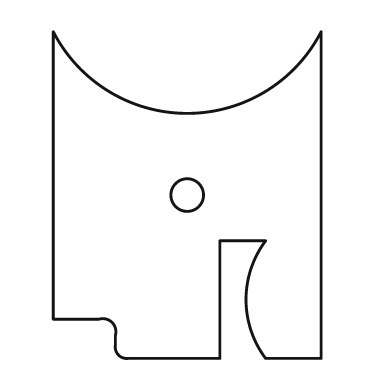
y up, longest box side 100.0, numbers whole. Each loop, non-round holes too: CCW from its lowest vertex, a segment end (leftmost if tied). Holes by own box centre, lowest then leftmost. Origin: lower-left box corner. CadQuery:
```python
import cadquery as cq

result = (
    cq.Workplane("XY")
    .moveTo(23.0, 0.0)
    .lineTo(51.0, 0.0)
    .lineTo(51.0, 36.0)
    .lineTo(65.0, 36.0)
    .threePointArc((59.0, 18.0), (65.0, 0.0))
    .lineTo(82.0, 0.0)
    .lineTo(82.0, 100.0)
    .threePointArc((41.0, 75.0), (0.0, 100.0))
    .lineTo(0.0, 12.0)
    .lineTo(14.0, 12.0)
    .threePointArc((18.0, 11.0), (19.0, 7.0))
    .lineTo(19.0, 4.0)
    .threePointArc((20.0, 1.0), (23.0, 0.0))
    .close()
    .moveTo(41.0, 50.0)
    .circle(5.0)
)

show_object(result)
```